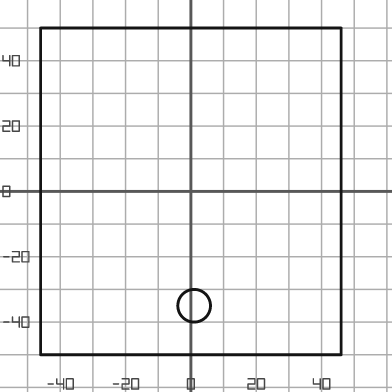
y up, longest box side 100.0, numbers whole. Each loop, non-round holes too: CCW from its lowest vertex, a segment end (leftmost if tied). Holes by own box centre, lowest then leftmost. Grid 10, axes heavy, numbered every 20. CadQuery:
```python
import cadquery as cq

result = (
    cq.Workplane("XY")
    .moveTo(-46.0, -50.0)
    .lineTo(46.0, -50.0)
    .lineTo(46.0, 50.0)
    .lineTo(-46.0, 50.0)
    .close()
    .moveTo(1.0, -35.0)
    .circle(5.0)
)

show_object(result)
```